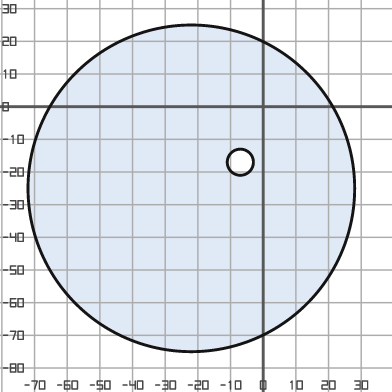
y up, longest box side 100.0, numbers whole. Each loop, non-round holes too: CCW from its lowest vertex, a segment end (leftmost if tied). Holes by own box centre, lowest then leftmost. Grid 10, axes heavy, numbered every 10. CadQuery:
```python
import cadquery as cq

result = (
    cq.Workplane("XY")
    .moveTo(-22.0, -25.0)
    .circle(50.0)
    .moveTo(-7.0, -17.0)
    .circle(4.0)
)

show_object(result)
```